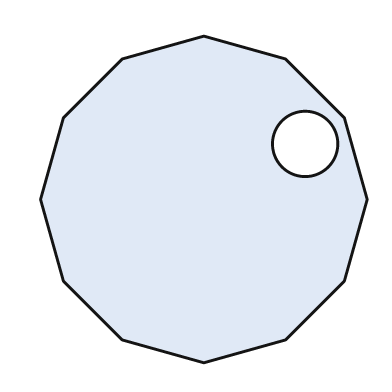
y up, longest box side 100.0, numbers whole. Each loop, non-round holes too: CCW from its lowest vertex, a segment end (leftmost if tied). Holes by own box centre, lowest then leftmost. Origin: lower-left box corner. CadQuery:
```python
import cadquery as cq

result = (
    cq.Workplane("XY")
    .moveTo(50.0, 0.0)
    .lineTo(75.0, 7.0)
    .lineTo(93.0, 25.0)
    .lineTo(100.0, 50.0)
    .lineTo(93.0, 75.0)
    .lineTo(75.0, 93.0)
    .lineTo(50.0, 100.0)
    .lineTo(25.0, 93.0)
    .lineTo(7.0, 75.0)
    .lineTo(0.0, 50.0)
    .lineTo(7.0, 25.0)
    .lineTo(25.0, 7.0)
    .close()
    .moveTo(81.0, 67.0)
    .circle(10.0)
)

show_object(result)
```